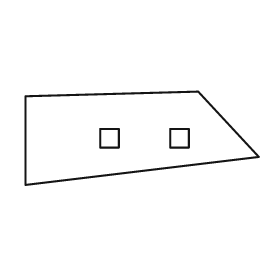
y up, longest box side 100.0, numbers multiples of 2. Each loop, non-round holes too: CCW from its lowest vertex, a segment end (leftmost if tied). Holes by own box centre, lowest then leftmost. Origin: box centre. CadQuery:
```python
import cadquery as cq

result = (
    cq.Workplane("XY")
    .moveTo(-50.0, -20.0)
    .lineTo(50.0, -8.0)
    .lineTo(24.0, 20.0)
    .lineTo(-50.0, 18.0)
    .close()
    .moveTo(-18.0, -4.0)
    .lineTo(-10.0, -4.0)
    .lineTo(-10.0, 4.0)
    .lineTo(-18.0, 4.0)
    .close()
    .moveTo(12.0, -4.0)
    .lineTo(20.0, -4.0)
    .lineTo(20.0, 4.0)
    .lineTo(12.0, 4.0)
    .close()
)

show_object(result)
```